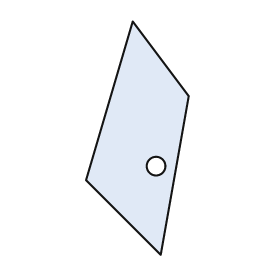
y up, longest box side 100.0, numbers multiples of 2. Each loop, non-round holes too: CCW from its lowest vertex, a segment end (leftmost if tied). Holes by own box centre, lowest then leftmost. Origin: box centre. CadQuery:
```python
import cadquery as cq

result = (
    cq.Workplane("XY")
    .moveTo(10.0, -50.0)
    .lineTo(22.0, 18.0)
    .lineTo(-2.0, 50.0)
    .lineTo(-22.0, -18.0)
    .close()
    .moveTo(8.0, -12.0)
    .circle(4.0)
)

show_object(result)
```